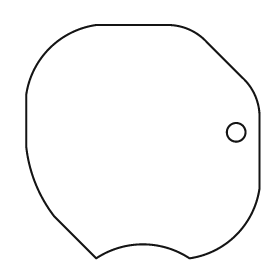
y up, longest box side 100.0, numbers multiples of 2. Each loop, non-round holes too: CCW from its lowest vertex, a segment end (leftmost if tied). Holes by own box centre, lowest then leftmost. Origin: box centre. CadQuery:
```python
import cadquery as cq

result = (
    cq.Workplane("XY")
    .moveTo(-20.0, -50.0)
    .threePointArc((0.0, -44.0), (20.0, -50.0))
    .threePointArc((40.0, -40.0), (50.0, -20.0))
    .lineTo(50.0, 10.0)
    .threePointArc((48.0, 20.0), (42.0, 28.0))
    .lineTo(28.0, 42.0)
    .threePointArc((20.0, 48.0), (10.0, 50.0))
    .lineTo(-20.0, 50.0)
    .threePointArc((-40.0, 40.0), (-50.0, 20.0))
    .lineTo(-50.0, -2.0)
    .threePointArc((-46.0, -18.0), (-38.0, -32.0))
    .close()
    .moveTo(40.0, 4.0)
    .circle(4.0)
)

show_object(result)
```